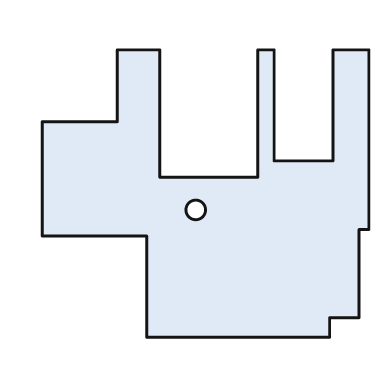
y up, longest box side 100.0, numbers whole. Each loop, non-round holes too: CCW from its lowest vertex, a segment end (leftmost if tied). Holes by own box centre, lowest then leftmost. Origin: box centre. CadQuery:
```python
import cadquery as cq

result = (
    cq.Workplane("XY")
    .moveTo(-18.0, -44.0)
    .lineTo(38.0, -44.0)
    .lineTo(38.0, -38.0)
    .lineTo(47.0, -38.0)
    .lineTo(47.0, -11.0)
    .lineTo(50.0, -11.0)
    .lineTo(50.0, 44.0)
    .lineTo(39.0, 44.0)
    .lineTo(39.0, 10.0)
    .lineTo(21.0, 10.0)
    .lineTo(21.0, 44.0)
    .lineTo(16.0, 44.0)
    .lineTo(16.0, 5.0)
    .lineTo(-14.0, 5.0)
    .lineTo(-14.0, 44.0)
    .lineTo(-27.0, 44.0)
    .lineTo(-27.0, 22.0)
    .lineTo(-50.0, 22.0)
    .lineTo(-50.0, -13.0)
    .lineTo(-18.0, -13.0)
    .close()
    .moveTo(-3.0, -5.0)
    .circle(3.0)
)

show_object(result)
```